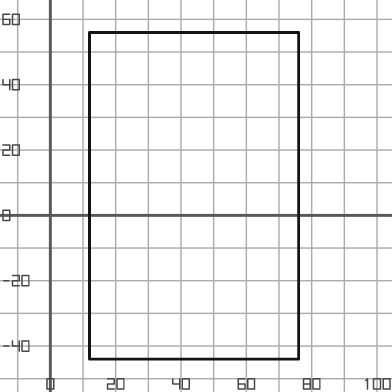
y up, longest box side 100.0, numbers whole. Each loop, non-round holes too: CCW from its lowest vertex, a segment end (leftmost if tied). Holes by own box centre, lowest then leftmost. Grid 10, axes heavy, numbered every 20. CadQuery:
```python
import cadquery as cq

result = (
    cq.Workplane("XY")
    .moveTo(12.0, -44.0)
    .lineTo(76.0, -44.0)
    .lineTo(76.0, 56.0)
    .lineTo(12.0, 56.0)
    .close()
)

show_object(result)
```